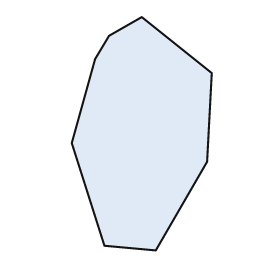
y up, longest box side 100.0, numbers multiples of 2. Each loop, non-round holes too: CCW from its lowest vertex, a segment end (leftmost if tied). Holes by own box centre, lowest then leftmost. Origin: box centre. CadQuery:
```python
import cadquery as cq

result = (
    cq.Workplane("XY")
    .moveTo(6.0, -50.0)
    .lineTo(28.0, -12.0)
    .lineTo(30.0, 26.0)
    .lineTo(0.0, 50.0)
    .lineTo(-14.0, 42.0)
    .lineTo(-20.0, 32.0)
    .lineTo(-30.0, -4.0)
    .lineTo(-16.0, -48.0)
    .close()
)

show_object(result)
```